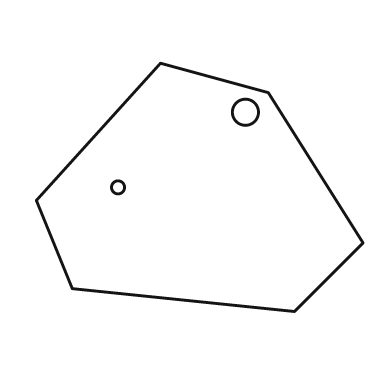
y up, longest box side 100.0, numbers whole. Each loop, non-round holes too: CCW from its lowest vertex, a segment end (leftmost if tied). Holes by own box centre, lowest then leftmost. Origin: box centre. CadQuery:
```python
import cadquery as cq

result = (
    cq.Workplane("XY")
    .moveTo(29.0, -38.0)
    .lineTo(50.0, -17.0)
    .lineTo(21.0, 29.0)
    .lineTo(-12.0, 38.0)
    .lineTo(-50.0, -4.0)
    .lineTo(-39.0, -31.0)
    .close()
    .moveTo(-25.0, 0.0)
    .circle(2.0)
    .moveTo(14.0, 23.0)
    .circle(4.0)
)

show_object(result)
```